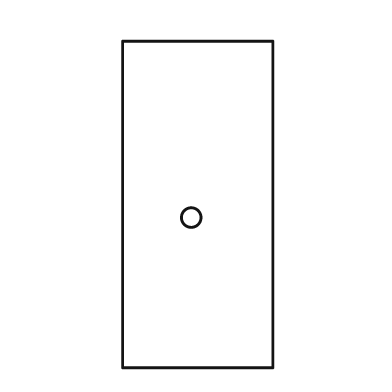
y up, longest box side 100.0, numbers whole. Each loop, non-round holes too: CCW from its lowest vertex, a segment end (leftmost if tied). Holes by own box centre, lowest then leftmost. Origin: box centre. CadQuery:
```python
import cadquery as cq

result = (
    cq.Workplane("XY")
    .moveTo(-23.0, -50.0)
    .lineTo(23.0, -50.0)
    .lineTo(23.0, 50.0)
    .lineTo(-23.0, 50.0)
    .close()
    .moveTo(-2.0, -4.0)
    .circle(3.0)
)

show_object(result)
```